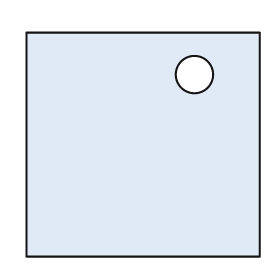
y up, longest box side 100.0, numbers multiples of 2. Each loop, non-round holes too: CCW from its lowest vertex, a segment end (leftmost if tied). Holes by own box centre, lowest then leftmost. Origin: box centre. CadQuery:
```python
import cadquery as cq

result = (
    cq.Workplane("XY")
    .moveTo(-50.0, -48.0)
    .lineTo(50.0, -48.0)
    .lineTo(50.0, 48.0)
    .lineTo(-50.0, 48.0)
    .close()
    .moveTo(22.0, 30.0)
    .circle(8.0)
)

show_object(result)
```